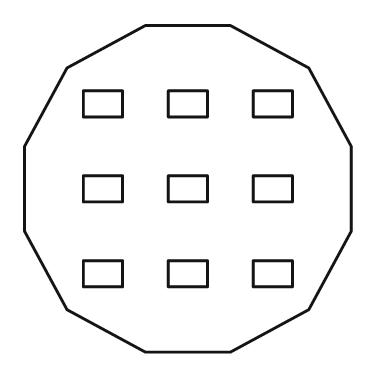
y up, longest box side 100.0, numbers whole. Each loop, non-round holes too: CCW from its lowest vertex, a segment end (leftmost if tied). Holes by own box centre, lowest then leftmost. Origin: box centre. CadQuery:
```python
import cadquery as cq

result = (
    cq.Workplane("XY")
    .moveTo(-13.0, -50.0)
    .lineTo(13.0, -50.0)
    .lineTo(37.0, -37.0)
    .lineTo(50.0, -13.0)
    .lineTo(50.0, 13.0)
    .lineTo(37.0, 37.0)
    .lineTo(13.0, 50.0)
    .lineTo(-13.0, 50.0)
    .lineTo(-37.0, 37.0)
    .lineTo(-50.0, 13.0)
    .lineTo(-50.0, -13.0)
    .lineTo(-37.0, -37.0)
    .close()
    .moveTo(-32.0, -30.0)
    .lineTo(-20.0, -30.0)
    .lineTo(-20.0, -22.0)
    .lineTo(-32.0, -22.0)
    .close()
    .moveTo(-6.0, -30.0)
    .lineTo(6.0, -30.0)
    .lineTo(6.0, -22.0)
    .lineTo(-6.0, -22.0)
    .close()
    .moveTo(20.0, -30.0)
    .lineTo(32.0, -30.0)
    .lineTo(32.0, -22.0)
    .lineTo(20.0, -22.0)
    .close()
    .moveTo(-32.0, -4.0)
    .lineTo(-20.0, -4.0)
    .lineTo(-20.0, 4.0)
    .lineTo(-32.0, 4.0)
    .close()
    .moveTo(-6.0, -4.0)
    .lineTo(6.0, -4.0)
    .lineTo(6.0, 4.0)
    .lineTo(-6.0, 4.0)
    .close()
    .moveTo(20.0, -4.0)
    .lineTo(32.0, -4.0)
    .lineTo(32.0, 4.0)
    .lineTo(20.0, 4.0)
    .close()
    .moveTo(-32.0, 22.0)
    .lineTo(-20.0, 22.0)
    .lineTo(-20.0, 30.0)
    .lineTo(-32.0, 30.0)
    .close()
    .moveTo(-6.0, 22.0)
    .lineTo(6.0, 22.0)
    .lineTo(6.0, 30.0)
    .lineTo(-6.0, 30.0)
    .close()
    .moveTo(20.0, 22.0)
    .lineTo(32.0, 22.0)
    .lineTo(32.0, 30.0)
    .lineTo(20.0, 30.0)
    .close()
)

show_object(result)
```